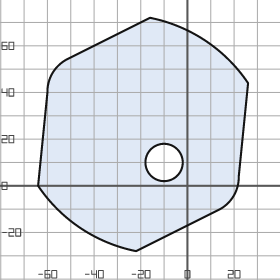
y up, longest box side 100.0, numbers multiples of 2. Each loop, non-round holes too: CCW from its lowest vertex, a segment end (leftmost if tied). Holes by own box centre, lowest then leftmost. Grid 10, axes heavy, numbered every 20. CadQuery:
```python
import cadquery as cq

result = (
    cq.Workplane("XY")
    .moveTo(-22.0, -28.0)
    .lineTo(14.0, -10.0)
    .threePointArc((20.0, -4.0), (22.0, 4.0))
    .lineTo(26.0, 44.0)
    .threePointArc((8.0, 62.0), (-16.0, 72.0))
    .lineTo(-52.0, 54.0)
    .threePointArc((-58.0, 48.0), (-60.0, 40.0))
    .lineTo(-64.0, 0.0)
    .threePointArc((-46.0, -18.0), (-22.0, -28.0))
    .close()
    .moveTo(-10.0, 10.0)
    .circle(8.0)
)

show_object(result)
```